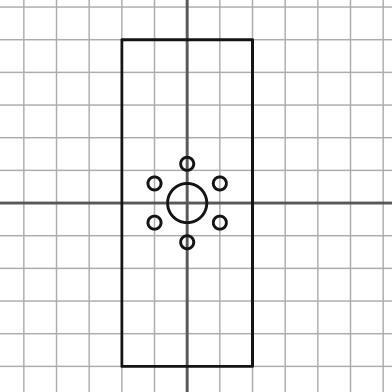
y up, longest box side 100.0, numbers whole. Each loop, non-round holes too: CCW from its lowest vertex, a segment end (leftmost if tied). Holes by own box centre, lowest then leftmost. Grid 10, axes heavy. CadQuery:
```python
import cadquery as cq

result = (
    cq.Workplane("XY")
    .moveTo(-20.0, -50.0)
    .lineTo(20.0, -50.0)
    .lineTo(20.0, 50.0)
    .lineTo(-20.0, 50.0)
    .close()
    .moveTo(0.0, -12.0)
    .circle(2.0)
    .moveTo(-10.0, -6.0)
    .circle(2.0)
    .moveTo(10.0, -6.0)
    .circle(2.0)
    .moveTo(0.0, 0.0)
    .circle(6.0)
    .moveTo(-10.0, 6.0)
    .circle(2.0)
    .moveTo(10.0, 6.0)
    .circle(2.0)
    .moveTo(0.0, 12.0)
    .circle(2.0)
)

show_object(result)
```